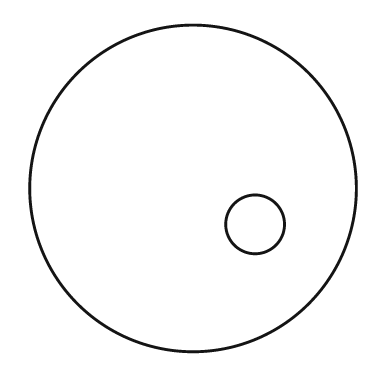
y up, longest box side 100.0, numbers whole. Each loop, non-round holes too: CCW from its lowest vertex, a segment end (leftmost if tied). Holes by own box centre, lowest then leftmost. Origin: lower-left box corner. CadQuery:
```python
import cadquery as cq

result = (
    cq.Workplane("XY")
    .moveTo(50.0, 50.0)
    .circle(50.0)
    .moveTo(69.0, 39.0)
    .circle(9.0)
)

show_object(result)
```